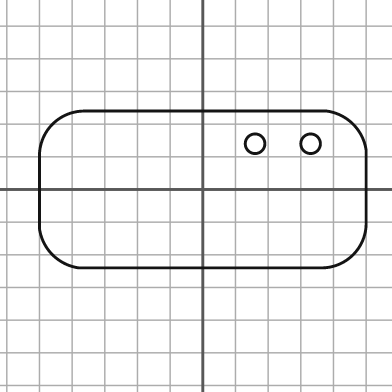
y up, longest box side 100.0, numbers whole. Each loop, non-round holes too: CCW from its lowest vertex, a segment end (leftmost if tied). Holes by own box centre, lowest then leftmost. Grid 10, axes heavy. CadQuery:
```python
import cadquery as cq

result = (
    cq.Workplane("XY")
    .moveTo(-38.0, -24.0)
    .lineTo(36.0, -24.0)
    .threePointArc((46.0, -20.0), (50.0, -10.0))
    .lineTo(50.0, 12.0)
    .threePointArc((46.0, 20.0), (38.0, 24.0))
    .lineTo(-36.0, 24.0)
    .threePointArc((-46.0, 20.0), (-50.0, 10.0))
    .lineTo(-50.0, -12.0)
    .threePointArc((-46.0, -20.0), (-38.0, -24.0))
    .close()
    .moveTo(16.0, 14.0)
    .circle(3.0)
    .moveTo(33.0, 14.0)
    .circle(3.0)
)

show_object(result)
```